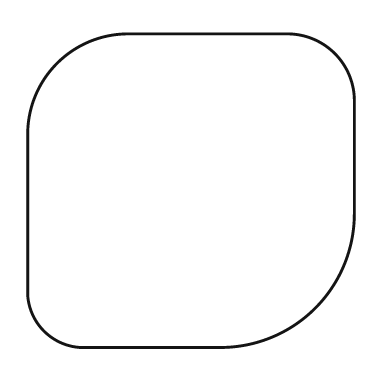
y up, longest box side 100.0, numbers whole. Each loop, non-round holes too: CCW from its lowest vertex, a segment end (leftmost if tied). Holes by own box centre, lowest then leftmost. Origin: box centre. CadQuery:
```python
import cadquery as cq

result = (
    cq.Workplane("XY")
    .moveTo(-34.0, -48.0)
    .lineTo(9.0, -48.0)
    .threePointArc((38.0, -36.0), (50.0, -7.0))
    .lineTo(50.0, 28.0)
    .threePointArc((44.0, 42.0), (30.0, 48.0))
    .lineTo(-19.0, 48.0)
    .threePointArc((-41.0, 39.0), (-50.0, 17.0))
    .lineTo(-50.0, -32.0)
    .threePointArc((-45.0, -43.0), (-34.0, -48.0))
    .close()
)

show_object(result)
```